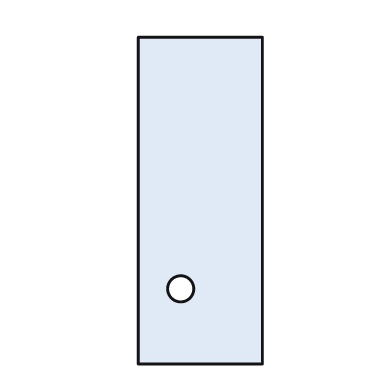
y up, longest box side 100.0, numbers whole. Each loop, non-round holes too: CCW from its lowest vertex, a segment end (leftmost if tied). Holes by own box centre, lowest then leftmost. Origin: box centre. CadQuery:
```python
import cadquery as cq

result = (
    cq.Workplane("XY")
    .moveTo(-19.0, -50.0)
    .lineTo(19.0, -50.0)
    .lineTo(19.0, 50.0)
    .lineTo(-19.0, 50.0)
    .close()
    .moveTo(-6.0, -27.0)
    .circle(4.0)
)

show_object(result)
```